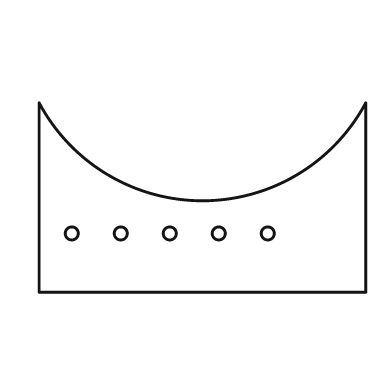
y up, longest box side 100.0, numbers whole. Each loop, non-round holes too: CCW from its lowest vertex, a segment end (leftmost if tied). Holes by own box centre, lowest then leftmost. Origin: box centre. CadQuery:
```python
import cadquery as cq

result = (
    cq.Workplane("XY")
    .moveTo(-50.0, -29.0)
    .lineTo(50.0, -29.0)
    .lineTo(50.0, 29.0)
    .threePointArc((0.0, -1.0), (-50.0, 29.0))
    .close()
    .moveTo(-40.0, -11.0)
    .circle(2.0)
    .moveTo(-25.0, -11.0)
    .circle(2.0)
    .moveTo(-10.0, -11.0)
    .circle(2.0)
    .moveTo(5.0, -11.0)
    .circle(2.0)
    .moveTo(20.0, -11.0)
    .circle(2.0)
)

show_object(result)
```